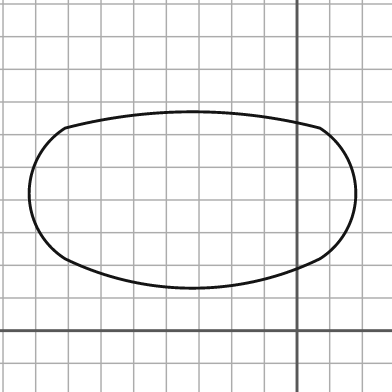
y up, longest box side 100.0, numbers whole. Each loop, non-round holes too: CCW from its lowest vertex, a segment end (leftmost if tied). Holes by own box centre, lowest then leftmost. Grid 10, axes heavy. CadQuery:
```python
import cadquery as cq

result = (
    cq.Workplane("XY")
    .moveTo(-71.0, 22.0)
    .threePointArc((-32.0, 13.0), (7.0, 22.0))
    .threePointArc((18.0, 42.0), (7.0, 62.0))
    .threePointArc((-32.0, 67.0), (-71.0, 62.0))
    .threePointArc((-82.0, 42.0), (-71.0, 22.0))
    .close()
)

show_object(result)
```